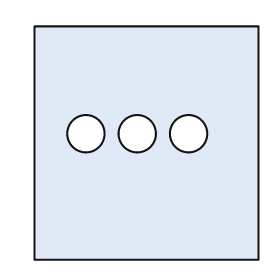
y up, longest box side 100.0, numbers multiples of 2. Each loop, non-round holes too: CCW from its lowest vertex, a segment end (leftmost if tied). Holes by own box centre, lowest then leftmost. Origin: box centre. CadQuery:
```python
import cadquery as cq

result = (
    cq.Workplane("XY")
    .moveTo(-48.0, -50.0)
    .lineTo(48.0, -50.0)
    .lineTo(48.0, 50.0)
    .lineTo(-48.0, 50.0)
    .close()
    .moveTo(-26.0, 4.0)
    .circle(8.0)
    .moveTo(-4.0, 4.0)
    .circle(8.0)
    .moveTo(18.0, 4.0)
    .circle(8.0)
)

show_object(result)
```